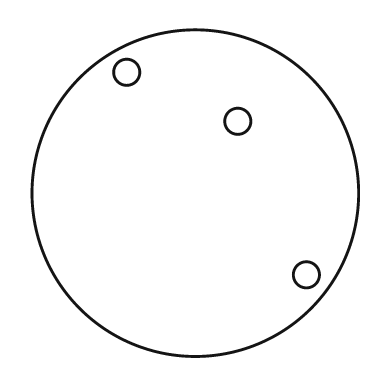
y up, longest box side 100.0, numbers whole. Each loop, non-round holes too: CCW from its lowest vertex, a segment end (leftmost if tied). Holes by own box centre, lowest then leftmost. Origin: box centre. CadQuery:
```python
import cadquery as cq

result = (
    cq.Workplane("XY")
    .moveTo(0.0, 0.0)
    .circle(50.0)
    .moveTo(34.0, -25.0)
    .circle(4.0)
    .moveTo(13.0, 22.0)
    .circle(4.0)
    .moveTo(-21.0, 37.0)
    .circle(4.0)
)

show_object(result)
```